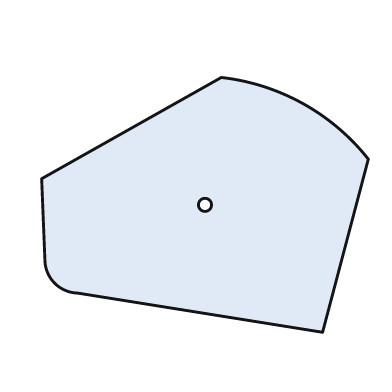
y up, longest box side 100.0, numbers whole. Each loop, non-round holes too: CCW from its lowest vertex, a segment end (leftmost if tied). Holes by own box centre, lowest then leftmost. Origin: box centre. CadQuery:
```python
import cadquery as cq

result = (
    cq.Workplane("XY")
    .moveTo(36.0, -39.0)
    .lineTo(50.0, 14.0)
    .threePointArc((30.0, 31.0), (5.0, 39.0))
    .lineTo(-50.0, 8.0)
    .lineTo(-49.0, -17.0)
    .threePointArc((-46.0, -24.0), (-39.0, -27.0))
    .close()
    .moveTo(0.0, 0.0)
    .circle(2.0)
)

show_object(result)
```